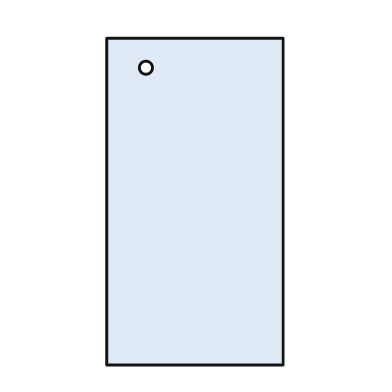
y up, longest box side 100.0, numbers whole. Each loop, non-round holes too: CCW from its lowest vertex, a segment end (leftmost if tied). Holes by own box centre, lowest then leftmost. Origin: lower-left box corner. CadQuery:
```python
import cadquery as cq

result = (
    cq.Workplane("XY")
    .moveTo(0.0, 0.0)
    .lineTo(54.0, 0.0)
    .lineTo(54.0, 100.0)
    .lineTo(0.0, 100.0)
    .close()
    .moveTo(12.0, 91.0)
    .circle(2.0)
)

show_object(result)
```